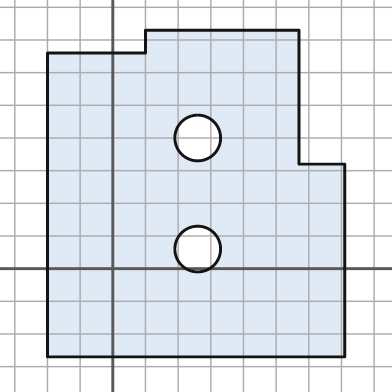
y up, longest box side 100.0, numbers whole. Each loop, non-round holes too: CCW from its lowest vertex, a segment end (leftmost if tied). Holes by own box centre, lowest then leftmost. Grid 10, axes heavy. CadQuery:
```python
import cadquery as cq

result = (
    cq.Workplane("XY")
    .moveTo(-20.0, -27.0)
    .lineTo(71.0, -27.0)
    .lineTo(71.0, 32.0)
    .lineTo(57.0, 32.0)
    .lineTo(57.0, 73.0)
    .lineTo(10.0, 73.0)
    .lineTo(10.0, 66.0)
    .lineTo(-20.0, 66.0)
    .close()
    .moveTo(26.0, 6.0)
    .circle(7.0)
    .moveTo(26.0, 40.0)
    .circle(7.0)
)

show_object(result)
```